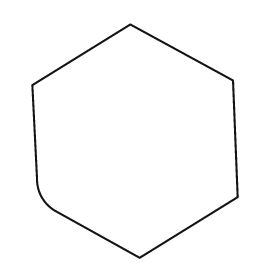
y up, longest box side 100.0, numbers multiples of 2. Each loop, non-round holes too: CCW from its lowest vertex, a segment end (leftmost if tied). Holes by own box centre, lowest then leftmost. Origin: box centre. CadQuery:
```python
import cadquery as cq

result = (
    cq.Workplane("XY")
    .moveTo(2.0, -50.0)
    .lineTo(44.0, -24.0)
    .lineTo(42.0, 26.0)
    .lineTo(-2.0, 50.0)
    .lineTo(-44.0, 24.0)
    .lineTo(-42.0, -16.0)
    .threePointArc((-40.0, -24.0), (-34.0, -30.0))
    .close()
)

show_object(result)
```